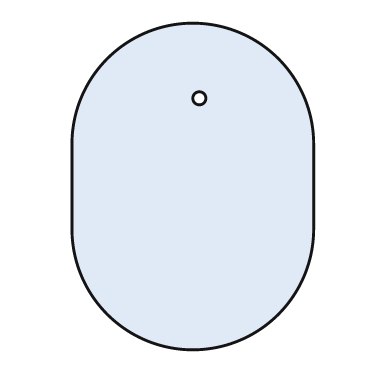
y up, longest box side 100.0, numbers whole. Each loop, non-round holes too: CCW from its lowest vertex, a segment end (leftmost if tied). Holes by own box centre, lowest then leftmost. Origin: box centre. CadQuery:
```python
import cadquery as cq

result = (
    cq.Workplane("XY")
    .moveTo(-37.0, -13.0)
    .threePointArc((0.0, -50.0), (37.0, -13.0))
    .lineTo(37.0, 13.0)
    .threePointArc((0.0, 50.0), (-37.0, 13.0))
    .close()
    .moveTo(2.0, 27.0)
    .circle(2.0)
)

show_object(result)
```